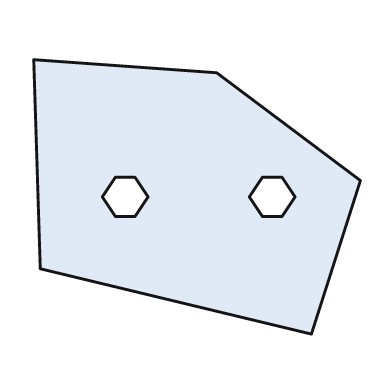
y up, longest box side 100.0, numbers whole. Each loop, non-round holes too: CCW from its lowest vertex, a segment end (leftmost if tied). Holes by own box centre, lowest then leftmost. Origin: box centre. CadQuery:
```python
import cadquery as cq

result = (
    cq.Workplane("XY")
    .moveTo(35.0, -42.0)
    .lineTo(50.0, 5.0)
    .lineTo(6.0, 38.0)
    .lineTo(-50.0, 42.0)
    .lineTo(-48.0, -22.0)
    .close()
    .moveTo(-25.0, -6.0)
    .lineTo(-19.0, -6.0)
    .lineTo(-15.0, 0.0)
    .lineTo(-19.0, 6.0)
    .lineTo(-25.0, 6.0)
    .lineTo(-29.0, 0.0)
    .close()
    .moveTo(20.0, -6.0)
    .lineTo(26.0, -6.0)
    .lineTo(30.0, 0.0)
    .lineTo(26.0, 6.0)
    .lineTo(20.0, 6.0)
    .lineTo(16.0, 0.0)
    .close()
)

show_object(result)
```